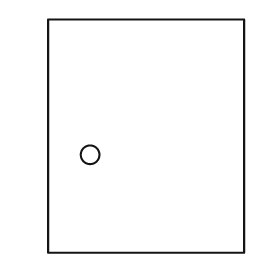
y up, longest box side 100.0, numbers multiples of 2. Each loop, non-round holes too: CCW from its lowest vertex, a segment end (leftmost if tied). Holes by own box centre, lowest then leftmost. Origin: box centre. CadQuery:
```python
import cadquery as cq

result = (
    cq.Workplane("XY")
    .moveTo(-42.0, -50.0)
    .lineTo(42.0, -50.0)
    .lineTo(42.0, 50.0)
    .lineTo(-42.0, 50.0)
    .close()
    .moveTo(-24.0, -8.0)
    .circle(4.0)
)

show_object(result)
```